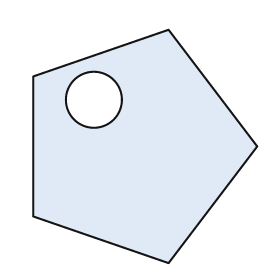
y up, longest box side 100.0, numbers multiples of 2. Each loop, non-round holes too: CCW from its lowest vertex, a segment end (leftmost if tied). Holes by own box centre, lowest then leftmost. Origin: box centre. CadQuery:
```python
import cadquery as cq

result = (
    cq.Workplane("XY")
    .moveTo(10.0, -50.0)
    .lineTo(48.0, 0.0)
    .lineTo(10.0, 50.0)
    .lineTo(-48.0, 30.0)
    .lineTo(-48.0, -30.0)
    .close()
    .moveTo(-22.0, 20.0)
    .circle(12.0)
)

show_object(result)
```